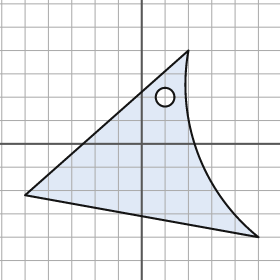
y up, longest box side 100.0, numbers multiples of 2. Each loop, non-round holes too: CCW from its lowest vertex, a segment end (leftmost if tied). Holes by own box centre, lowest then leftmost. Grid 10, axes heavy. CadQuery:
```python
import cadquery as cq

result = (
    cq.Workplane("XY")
    .moveTo(50.0, -40.0)
    .threePointArc((24.0, -4.0), (20.0, 40.0))
    .lineTo(-50.0, -22.0)
    .close()
    .moveTo(10.0, 20.0)
    .circle(4.0)
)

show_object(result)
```